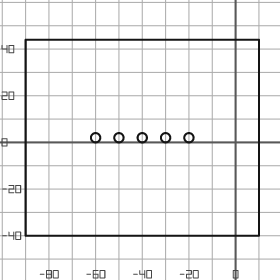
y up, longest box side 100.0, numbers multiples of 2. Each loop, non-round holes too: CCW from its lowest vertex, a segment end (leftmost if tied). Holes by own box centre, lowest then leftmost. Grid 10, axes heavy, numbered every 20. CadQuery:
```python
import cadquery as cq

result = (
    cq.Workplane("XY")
    .moveTo(-90.0, -40.0)
    .lineTo(10.0, -40.0)
    .lineTo(10.0, 44.0)
    .lineTo(-90.0, 44.0)
    .close()
    .moveTo(-60.0, 2.0)
    .circle(2.0)
    .moveTo(-50.0, 2.0)
    .circle(2.0)
    .moveTo(-40.0, 2.0)
    .circle(2.0)
    .moveTo(-30.0, 2.0)
    .circle(2.0)
    .moveTo(-20.0, 2.0)
    .circle(2.0)
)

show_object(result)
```